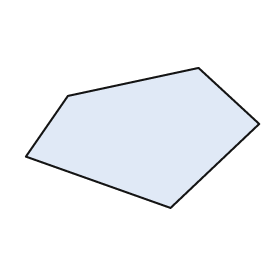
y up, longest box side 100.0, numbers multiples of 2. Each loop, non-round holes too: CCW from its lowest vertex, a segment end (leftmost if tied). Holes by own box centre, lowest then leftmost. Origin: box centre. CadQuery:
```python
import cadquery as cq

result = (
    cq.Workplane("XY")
    .moveTo(12.0, -30.0)
    .lineTo(50.0, 6.0)
    .lineTo(24.0, 30.0)
    .lineTo(-32.0, 18.0)
    .lineTo(-50.0, -8.0)
    .close()
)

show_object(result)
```